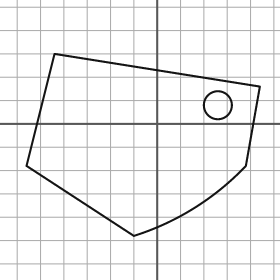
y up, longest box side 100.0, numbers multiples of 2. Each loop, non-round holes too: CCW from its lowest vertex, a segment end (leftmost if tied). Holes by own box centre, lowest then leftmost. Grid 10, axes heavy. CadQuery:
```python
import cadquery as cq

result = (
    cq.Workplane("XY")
    .moveTo(-10.0, -48.0)
    .threePointArc((16.0, -36.0), (38.0, -18.0))
    .lineTo(44.0, 16.0)
    .lineTo(-44.0, 30.0)
    .lineTo(-56.0, -18.0)
    .close()
    .moveTo(26.0, 8.0)
    .circle(6.0)
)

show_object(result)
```